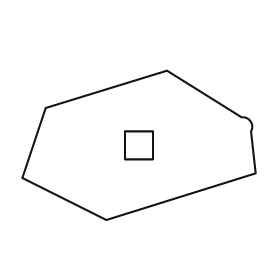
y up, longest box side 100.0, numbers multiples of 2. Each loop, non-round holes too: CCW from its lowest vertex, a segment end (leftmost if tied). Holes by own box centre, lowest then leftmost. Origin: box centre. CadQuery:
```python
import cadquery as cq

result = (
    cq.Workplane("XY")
    .moveTo(-14.0, -32.0)
    .lineTo(50.0, -12.0)
    .lineTo(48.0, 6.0)
    .threePointArc((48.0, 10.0), (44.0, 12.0))
    .lineTo(12.0, 32.0)
    .lineTo(-40.0, 16.0)
    .lineTo(-50.0, -14.0)
    .close()
    .moveTo(-6.0, -6.0)
    .lineTo(6.0, -6.0)
    .lineTo(6.0, 6.0)
    .lineTo(-6.0, 6.0)
    .close()
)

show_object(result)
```